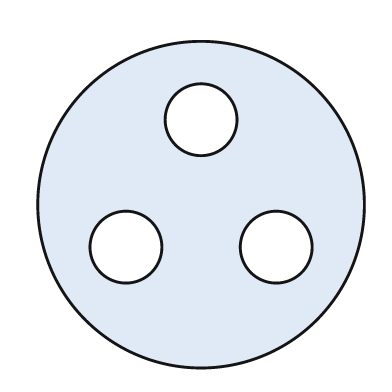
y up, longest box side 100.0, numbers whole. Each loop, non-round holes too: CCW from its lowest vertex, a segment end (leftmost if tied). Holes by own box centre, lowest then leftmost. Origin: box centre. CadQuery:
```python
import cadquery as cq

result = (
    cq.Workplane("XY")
    .moveTo(0.0, 0.0)
    .circle(50.0)
    .moveTo(-23.0, -13.0)
    .circle(11.0)
    .moveTo(23.0, -13.0)
    .circle(11.0)
    .moveTo(0.0, 26.0)
    .circle(11.0)
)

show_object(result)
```